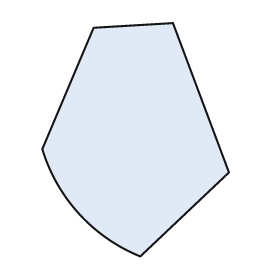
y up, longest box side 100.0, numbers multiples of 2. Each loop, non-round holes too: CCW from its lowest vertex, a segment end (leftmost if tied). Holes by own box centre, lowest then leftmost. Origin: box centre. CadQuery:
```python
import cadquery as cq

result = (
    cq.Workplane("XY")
    .moveTo(2.0, -50.0)
    .lineTo(40.0, -14.0)
    .lineTo(16.0, 50.0)
    .lineTo(-18.0, 48.0)
    .lineTo(-40.0, -4.0)
    .threePointArc((-24.0, -32.0), (2.0, -50.0))
    .close()
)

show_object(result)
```